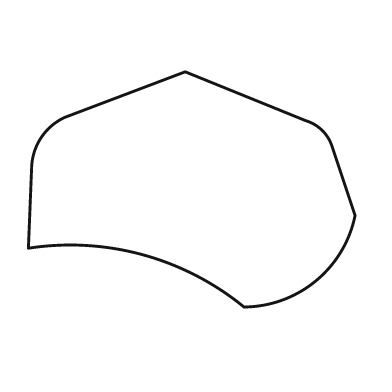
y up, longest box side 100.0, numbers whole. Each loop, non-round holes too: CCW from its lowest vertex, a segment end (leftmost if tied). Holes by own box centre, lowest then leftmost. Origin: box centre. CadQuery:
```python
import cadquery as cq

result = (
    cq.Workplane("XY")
    .moveTo(16.0, -36.0)
    .threePointArc((38.0, -28.0), (50.0, -8.0))
    .lineTo(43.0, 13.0)
    .threePointArc((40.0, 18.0), (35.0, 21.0))
    .lineTo(-2.0, 36.0)
    .lineTo(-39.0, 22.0)
    .threePointArc((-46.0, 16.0), (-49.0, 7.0))
    .lineTo(-50.0, -18.0)
    .threePointArc((-15.0, -20.0), (16.0, -36.0))
    .close()
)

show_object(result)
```